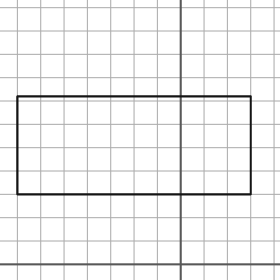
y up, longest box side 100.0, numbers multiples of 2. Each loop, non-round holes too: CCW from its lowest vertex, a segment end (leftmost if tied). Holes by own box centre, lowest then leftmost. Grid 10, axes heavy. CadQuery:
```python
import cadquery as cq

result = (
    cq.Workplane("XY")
    .moveTo(-70.0, 30.0)
    .lineTo(30.0, 30.0)
    .lineTo(30.0, 72.0)
    .lineTo(-70.0, 72.0)
    .close()
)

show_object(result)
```